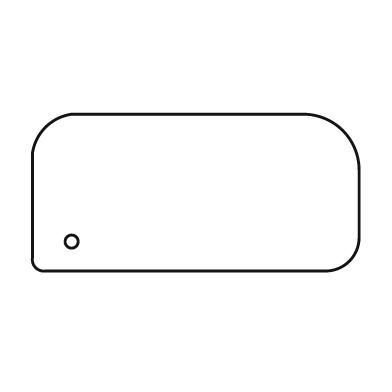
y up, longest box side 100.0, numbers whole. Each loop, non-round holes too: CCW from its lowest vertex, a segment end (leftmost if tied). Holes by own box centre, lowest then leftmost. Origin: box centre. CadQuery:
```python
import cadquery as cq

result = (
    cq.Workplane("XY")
    .moveTo(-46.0, -24.0)
    .lineTo(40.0, -24.0)
    .threePointArc((47.0, -21.0), (50.0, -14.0))
    .lineTo(50.0, 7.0)
    .threePointArc((45.0, 19.0), (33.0, 24.0))
    .lineTo(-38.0, 24.0)
    .threePointArc((-46.0, 20.0), (-50.0, 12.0))
    .lineTo(-50.0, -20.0)
    .threePointArc((-49.0, -23.0), (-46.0, -24.0))
    .close()
    .moveTo(-38.0, -15.0)
    .circle(2.0)
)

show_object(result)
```